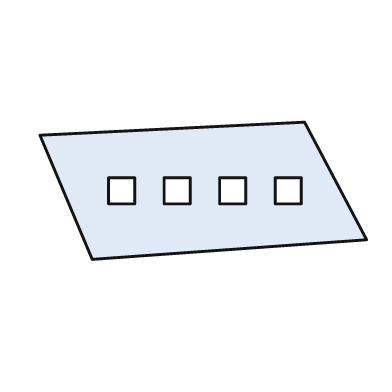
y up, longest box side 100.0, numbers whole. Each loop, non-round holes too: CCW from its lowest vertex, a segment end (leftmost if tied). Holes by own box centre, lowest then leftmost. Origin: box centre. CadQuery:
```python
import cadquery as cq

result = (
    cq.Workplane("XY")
    .moveTo(-34.0, -21.0)
    .lineTo(50.0, -15.0)
    .lineTo(31.0, 21.0)
    .lineTo(-50.0, 17.0)
    .close()
    .moveTo(-29.0, -4.0)
    .lineTo(-21.0, -4.0)
    .lineTo(-21.0, 4.0)
    .lineTo(-29.0, 4.0)
    .close()
    .moveTo(-12.0, -4.0)
    .lineTo(-4.0, -4.0)
    .lineTo(-4.0, 4.0)
    .lineTo(-12.0, 4.0)
    .close()
    .moveTo(5.0, -4.0)
    .lineTo(13.0, -4.0)
    .lineTo(13.0, 4.0)
    .lineTo(5.0, 4.0)
    .close()
    .moveTo(22.0, -4.0)
    .lineTo(30.0, -4.0)
    .lineTo(30.0, 4.0)
    .lineTo(22.0, 4.0)
    .close()
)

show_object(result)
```